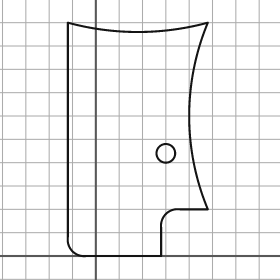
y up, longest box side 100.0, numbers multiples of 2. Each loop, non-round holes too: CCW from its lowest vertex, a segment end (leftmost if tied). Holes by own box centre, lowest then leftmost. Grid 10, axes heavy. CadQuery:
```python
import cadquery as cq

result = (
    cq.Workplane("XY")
    .moveTo(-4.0, 0.0)
    .lineTo(28.0, 0.0)
    .lineTo(28.0, 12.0)
    .threePointArc((30.0, 18.0), (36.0, 20.0))
    .lineTo(48.0, 20.0)
    .threePointArc((40.0, 60.0), (48.0, 100.0))
    .threePointArc((18.0, 96.0), (-12.0, 100.0))
    .lineTo(-12.0, 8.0)
    .threePointArc((-10.0, 2.0), (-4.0, 0.0))
    .close()
    .moveTo(30.0, 44.0)
    .circle(4.0)
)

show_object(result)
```